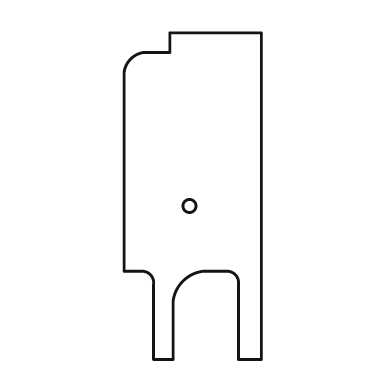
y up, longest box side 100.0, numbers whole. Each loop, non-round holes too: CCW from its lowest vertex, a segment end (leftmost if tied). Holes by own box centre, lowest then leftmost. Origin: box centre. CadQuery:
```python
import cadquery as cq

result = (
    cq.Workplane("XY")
    .moveTo(-12.0, -50.0)
    .lineTo(-6.0, -50.0)
    .lineTo(-6.0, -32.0)
    .threePointArc((-3.0, -26.0), (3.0, -23.0))
    .lineTo(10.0, -23.0)
    .threePointArc((13.0, -24.0), (14.0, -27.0))
    .lineTo(14.0, -50.0)
    .lineTo(21.0, -50.0)
    .lineTo(21.0, 50.0)
    .lineTo(-7.0, 50.0)
    .lineTo(-7.0, 44.0)
    .lineTo(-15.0, 44.0)
    .threePointArc((-19.0, 42.0), (-21.0, 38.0))
    .lineTo(-21.0, -23.0)
    .lineTo(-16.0, -23.0)
    .threePointArc((-13.0, -24.0), (-12.0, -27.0))
    .close()
    .moveTo(-1.0, -3.0)
    .circle(2.0)
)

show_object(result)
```